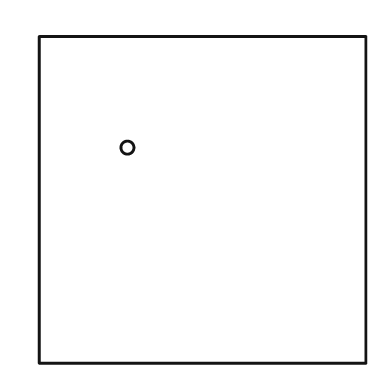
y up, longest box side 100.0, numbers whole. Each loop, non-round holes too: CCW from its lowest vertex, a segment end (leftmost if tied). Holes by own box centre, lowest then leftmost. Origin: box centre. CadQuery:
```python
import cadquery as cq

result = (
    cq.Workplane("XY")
    .moveTo(-50.0, -50.0)
    .lineTo(50.0, -50.0)
    .lineTo(50.0, 50.0)
    .lineTo(-50.0, 50.0)
    .close()
    .moveTo(-23.0, 16.0)
    .circle(2.0)
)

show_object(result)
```